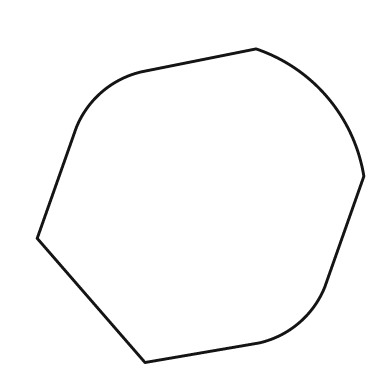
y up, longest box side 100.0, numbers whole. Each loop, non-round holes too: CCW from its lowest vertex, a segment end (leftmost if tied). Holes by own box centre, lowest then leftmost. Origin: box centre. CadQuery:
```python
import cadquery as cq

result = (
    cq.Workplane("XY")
    .moveTo(-17.0, -48.0)
    .lineTo(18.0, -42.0)
    .threePointArc((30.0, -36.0), (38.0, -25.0))
    .lineTo(50.0, 9.0)
    .threePointArc((39.0, 33.0), (17.0, 48.0))
    .lineTo(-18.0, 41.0)
    .threePointArc((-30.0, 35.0), (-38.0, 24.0))
    .lineTo(-50.0, -10.0)
    .close()
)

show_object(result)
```